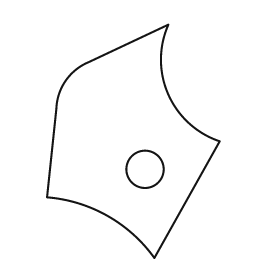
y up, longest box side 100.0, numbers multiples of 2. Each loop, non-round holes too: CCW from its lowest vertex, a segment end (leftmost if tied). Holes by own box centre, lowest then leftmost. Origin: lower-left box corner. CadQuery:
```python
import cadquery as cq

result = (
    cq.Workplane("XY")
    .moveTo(46.0, 0.0)
    .lineTo(74.0, 50.0)
    .threePointArc((52.0, 70.0), (52.0, 100.0))
    .lineTo(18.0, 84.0)
    .threePointArc((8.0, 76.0), (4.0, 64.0))
    .lineTo(0.0, 26.0)
    .threePointArc((26.0, 18.0), (46.0, 0.0))
    .close()
    .moveTo(42.0, 38.0)
    .circle(8.0)
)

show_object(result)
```